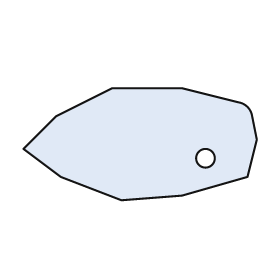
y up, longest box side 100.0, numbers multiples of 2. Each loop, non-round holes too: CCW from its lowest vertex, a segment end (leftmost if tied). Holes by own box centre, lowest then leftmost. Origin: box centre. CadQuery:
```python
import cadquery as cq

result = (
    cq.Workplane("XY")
    .moveTo(-8.0, -24.0)
    .lineTo(18.0, -22.0)
    .lineTo(46.0, -14.0)
    .lineTo(50.0, 2.0)
    .lineTo(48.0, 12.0)
    .threePointArc((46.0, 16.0), (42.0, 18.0))
    .lineTo(18.0, 24.0)
    .lineTo(-12.0, 24.0)
    .lineTo(-36.0, 12.0)
    .lineTo(-50.0, -2.0)
    .lineTo(-34.0, -14.0)
    .close()
    .moveTo(28.0, -6.0)
    .circle(4.0)
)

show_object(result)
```